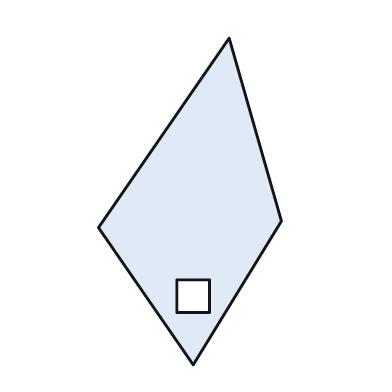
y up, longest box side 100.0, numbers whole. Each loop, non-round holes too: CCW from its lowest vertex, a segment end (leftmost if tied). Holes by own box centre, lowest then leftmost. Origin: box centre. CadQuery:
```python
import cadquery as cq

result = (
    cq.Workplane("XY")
    .moveTo(1.0, -50.0)
    .lineTo(28.0, -6.0)
    .lineTo(12.0, 50.0)
    .lineTo(-28.0, -8.0)
    .close()
    .moveTo(-4.0, -34.0)
    .lineTo(6.0, -34.0)
    .lineTo(6.0, -24.0)
    .lineTo(-4.0, -24.0)
    .close()
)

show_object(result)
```